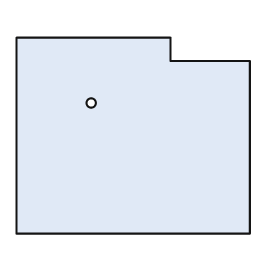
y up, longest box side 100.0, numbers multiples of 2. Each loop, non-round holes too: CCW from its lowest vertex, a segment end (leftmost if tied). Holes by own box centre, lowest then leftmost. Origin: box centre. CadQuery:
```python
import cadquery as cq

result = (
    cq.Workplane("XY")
    .moveTo(-50.0, -42.0)
    .lineTo(50.0, -42.0)
    .lineTo(50.0, 32.0)
    .lineTo(16.0, 32.0)
    .lineTo(16.0, 42.0)
    .lineTo(-50.0, 42.0)
    .close()
    .moveTo(-18.0, 14.0)
    .circle(2.0)
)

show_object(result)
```